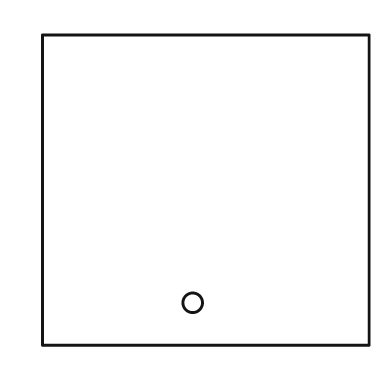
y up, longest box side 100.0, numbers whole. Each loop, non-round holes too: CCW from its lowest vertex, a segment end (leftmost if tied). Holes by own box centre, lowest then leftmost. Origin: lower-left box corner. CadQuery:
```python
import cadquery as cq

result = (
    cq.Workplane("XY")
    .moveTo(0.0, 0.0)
    .lineTo(100.0, 0.0)
    .lineTo(100.0, 95.0)
    .lineTo(0.0, 95.0)
    .close()
    .moveTo(46.0, 13.0)
    .circle(3.0)
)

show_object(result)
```